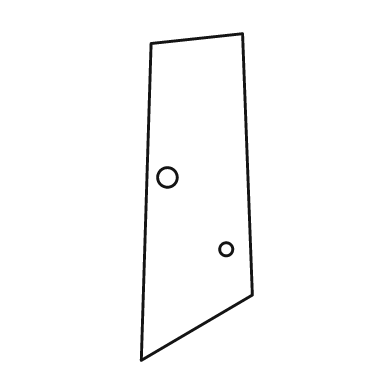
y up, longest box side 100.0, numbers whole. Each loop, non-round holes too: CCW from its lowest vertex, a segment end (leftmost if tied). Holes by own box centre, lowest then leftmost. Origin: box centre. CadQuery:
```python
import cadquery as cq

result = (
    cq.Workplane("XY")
    .moveTo(-17.0, -50.0)
    .lineTo(17.0, -30.0)
    .lineTo(14.0, 50.0)
    .lineTo(-14.0, 47.0)
    .close()
    .moveTo(9.0, -16.0)
    .circle(2.0)
    .moveTo(-9.0, 6.0)
    .circle(3.0)
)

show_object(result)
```